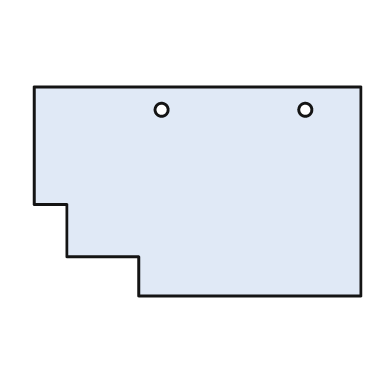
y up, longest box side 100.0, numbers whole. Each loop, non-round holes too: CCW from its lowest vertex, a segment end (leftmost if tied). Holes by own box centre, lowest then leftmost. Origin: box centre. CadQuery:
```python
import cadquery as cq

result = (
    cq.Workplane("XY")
    .moveTo(-18.0, -32.0)
    .lineTo(50.0, -32.0)
    .lineTo(50.0, 32.0)
    .lineTo(-50.0, 32.0)
    .lineTo(-50.0, -4.0)
    .lineTo(-40.0, -4.0)
    .lineTo(-40.0, -20.0)
    .lineTo(-18.0, -20.0)
    .close()
    .moveTo(-11.0, 25.0)
    .circle(2.0)
    .moveTo(33.0, 25.0)
    .circle(2.0)
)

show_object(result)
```